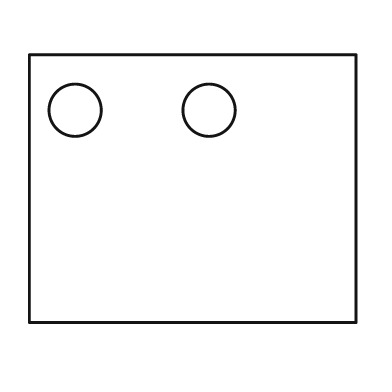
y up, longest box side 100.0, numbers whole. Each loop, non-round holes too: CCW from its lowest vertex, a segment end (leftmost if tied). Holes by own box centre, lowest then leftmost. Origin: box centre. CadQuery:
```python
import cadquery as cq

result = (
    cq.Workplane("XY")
    .moveTo(-50.0, -41.0)
    .lineTo(50.0, -41.0)
    .lineTo(50.0, 41.0)
    .lineTo(-50.0, 41.0)
    .close()
    .moveTo(-36.0, 24.0)
    .circle(8.0)
    .moveTo(5.0, 24.0)
    .circle(8.0)
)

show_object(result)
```